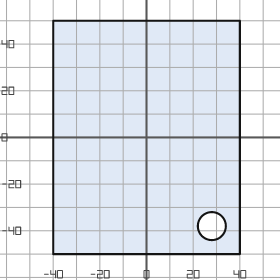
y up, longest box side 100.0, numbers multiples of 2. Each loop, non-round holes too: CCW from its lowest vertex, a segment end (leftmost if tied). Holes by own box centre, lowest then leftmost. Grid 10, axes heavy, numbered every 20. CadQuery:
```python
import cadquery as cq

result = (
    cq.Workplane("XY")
    .moveTo(-40.0, -50.0)
    .lineTo(40.0, -50.0)
    .lineTo(40.0, 50.0)
    .lineTo(-40.0, 50.0)
    .close()
    .moveTo(28.0, -38.0)
    .circle(6.0)
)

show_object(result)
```